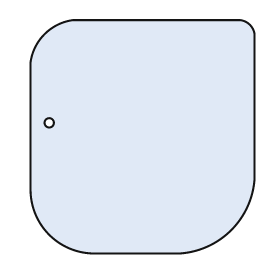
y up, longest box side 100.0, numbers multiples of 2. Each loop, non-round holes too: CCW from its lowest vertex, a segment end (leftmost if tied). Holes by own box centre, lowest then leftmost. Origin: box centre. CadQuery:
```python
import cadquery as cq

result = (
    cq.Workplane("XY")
    .moveTo(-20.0, -50.0)
    .lineTo(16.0, -50.0)
    .threePointArc((38.0, -40.0), (48.0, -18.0))
    .lineTo(48.0, 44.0)
    .threePointArc((46.0, 48.0), (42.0, 50.0))
    .lineTo(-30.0, 50.0)
    .threePointArc((-42.0, 44.0), (-48.0, 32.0))
    .lineTo(-48.0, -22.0)
    .threePointArc((-40.0, -42.0), (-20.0, -50.0))
    .close()
    .moveTo(-40.0, 6.0)
    .circle(2.0)
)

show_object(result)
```